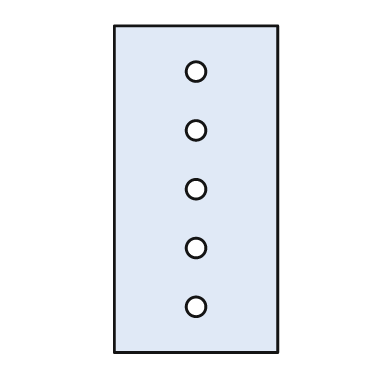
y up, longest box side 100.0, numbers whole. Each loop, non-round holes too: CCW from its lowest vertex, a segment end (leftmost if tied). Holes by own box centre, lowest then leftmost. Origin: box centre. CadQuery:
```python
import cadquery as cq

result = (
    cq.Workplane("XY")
    .moveTo(-25.0, -50.0)
    .lineTo(25.0, -50.0)
    .lineTo(25.0, 50.0)
    .lineTo(-25.0, 50.0)
    .close()
    .moveTo(0.0, -36.0)
    .circle(3.0)
    .moveTo(0.0, -18.0)
    .circle(3.0)
    .moveTo(0.0, 0.0)
    .circle(3.0)
    .moveTo(0.0, 18.0)
    .circle(3.0)
    .moveTo(0.0, 36.0)
    .circle(3.0)
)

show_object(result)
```